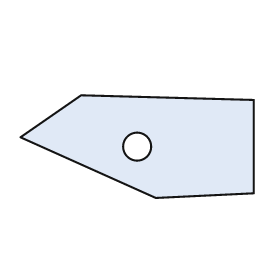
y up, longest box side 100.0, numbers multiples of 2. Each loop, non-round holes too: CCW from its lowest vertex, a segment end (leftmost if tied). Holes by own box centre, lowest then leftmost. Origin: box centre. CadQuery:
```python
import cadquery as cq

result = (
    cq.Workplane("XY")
    .moveTo(8.0, -22.0)
    .lineTo(50.0, -20.0)
    .lineTo(50.0, 20.0)
    .lineTo(-24.0, 22.0)
    .lineTo(-50.0, 4.0)
    .close()
    .moveTo(0.0, 0.0)
    .circle(6.0)
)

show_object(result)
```